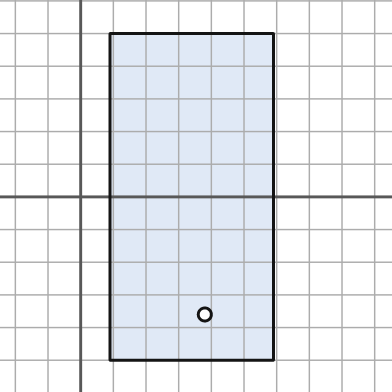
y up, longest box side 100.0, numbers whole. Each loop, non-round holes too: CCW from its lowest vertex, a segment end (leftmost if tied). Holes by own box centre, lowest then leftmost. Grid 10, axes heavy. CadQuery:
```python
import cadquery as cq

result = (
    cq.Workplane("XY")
    .moveTo(9.0, -50.0)
    .lineTo(59.0, -50.0)
    .lineTo(59.0, 50.0)
    .lineTo(9.0, 50.0)
    .close()
    .moveTo(38.0, -36.0)
    .circle(2.0)
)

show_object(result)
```